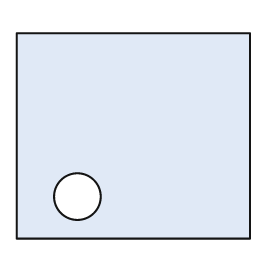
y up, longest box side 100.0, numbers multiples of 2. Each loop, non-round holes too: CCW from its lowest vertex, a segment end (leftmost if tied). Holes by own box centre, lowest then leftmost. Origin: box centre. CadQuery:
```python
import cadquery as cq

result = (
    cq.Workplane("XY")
    .moveTo(-50.0, -44.0)
    .lineTo(50.0, -44.0)
    .lineTo(50.0, 44.0)
    .lineTo(-50.0, 44.0)
    .close()
    .moveTo(-24.0, -26.0)
    .circle(10.0)
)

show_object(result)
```